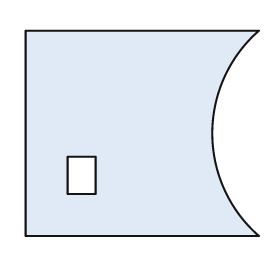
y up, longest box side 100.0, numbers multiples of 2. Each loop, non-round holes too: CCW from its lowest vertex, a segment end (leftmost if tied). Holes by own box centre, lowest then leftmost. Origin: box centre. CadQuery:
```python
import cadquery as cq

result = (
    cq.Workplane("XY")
    .moveTo(-50.0, -44.0)
    .lineTo(50.0, -44.0)
    .threePointArc((30.0, 0.0), (50.0, 44.0))
    .lineTo(-50.0, 44.0)
    .close()
    .moveTo(-32.0, -26.0)
    .lineTo(-20.0, -26.0)
    .lineTo(-20.0, -10.0)
    .lineTo(-32.0, -10.0)
    .close()
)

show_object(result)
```